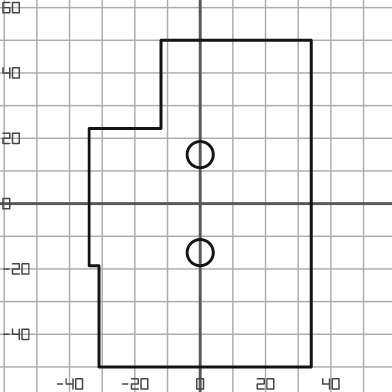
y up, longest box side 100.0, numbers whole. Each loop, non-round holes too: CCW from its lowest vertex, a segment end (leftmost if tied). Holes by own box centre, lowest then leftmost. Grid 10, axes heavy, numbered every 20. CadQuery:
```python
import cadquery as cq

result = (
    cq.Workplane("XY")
    .moveTo(-31.0, -50.0)
    .lineTo(34.0, -50.0)
    .lineTo(34.0, 50.0)
    .lineTo(-12.0, 50.0)
    .lineTo(-12.0, 23.0)
    .lineTo(-34.0, 23.0)
    .lineTo(-34.0, -19.0)
    .lineTo(-31.0, -19.0)
    .close()
    .moveTo(0.0, -15.0)
    .circle(4.0)
    .moveTo(0.0, 15.0)
    .circle(4.0)
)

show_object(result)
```